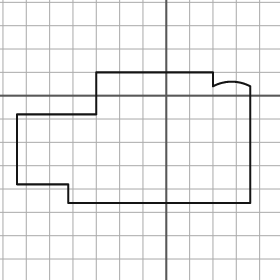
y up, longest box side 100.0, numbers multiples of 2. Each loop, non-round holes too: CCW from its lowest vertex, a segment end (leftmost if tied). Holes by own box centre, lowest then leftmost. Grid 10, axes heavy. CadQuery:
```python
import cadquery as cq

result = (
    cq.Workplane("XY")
    .moveTo(-42.0, -46.0)
    .lineTo(36.0, -46.0)
    .lineTo(36.0, 4.0)
    .threePointArc((28.0, 6.0), (20.0, 4.0))
    .lineTo(20.0, 10.0)
    .lineTo(-30.0, 10.0)
    .lineTo(-30.0, -8.0)
    .lineTo(-64.0, -8.0)
    .lineTo(-64.0, -38.0)
    .lineTo(-42.0, -38.0)
    .close()
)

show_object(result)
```